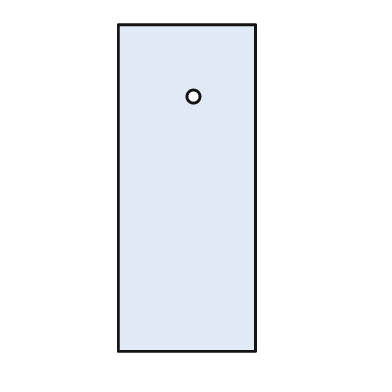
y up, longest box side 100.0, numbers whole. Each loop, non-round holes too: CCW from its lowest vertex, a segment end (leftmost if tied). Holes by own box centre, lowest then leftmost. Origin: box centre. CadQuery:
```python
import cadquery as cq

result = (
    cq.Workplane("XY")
    .moveTo(-21.0, -50.0)
    .lineTo(21.0, -50.0)
    .lineTo(21.0, 50.0)
    .lineTo(-21.0, 50.0)
    .close()
    .moveTo(2.0, 28.0)
    .circle(2.0)
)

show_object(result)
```